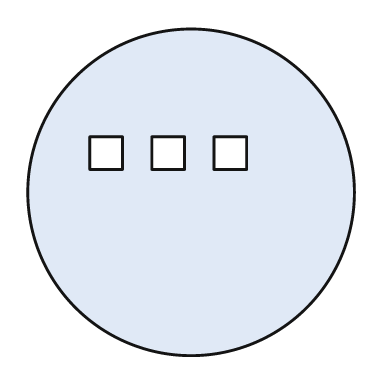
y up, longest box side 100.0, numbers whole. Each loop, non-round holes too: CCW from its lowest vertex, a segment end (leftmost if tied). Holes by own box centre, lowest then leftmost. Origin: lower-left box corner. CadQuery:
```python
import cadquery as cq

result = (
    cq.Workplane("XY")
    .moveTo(50.0, 50.0)
    .circle(50.0)
    .moveTo(19.0, 57.0)
    .lineTo(29.0, 57.0)
    .lineTo(29.0, 67.0)
    .lineTo(19.0, 67.0)
    .close()
    .moveTo(38.0, 57.0)
    .lineTo(48.0, 57.0)
    .lineTo(48.0, 67.0)
    .lineTo(38.0, 67.0)
    .close()
    .moveTo(57.0, 57.0)
    .lineTo(67.0, 57.0)
    .lineTo(67.0, 67.0)
    .lineTo(57.0, 67.0)
    .close()
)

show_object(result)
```